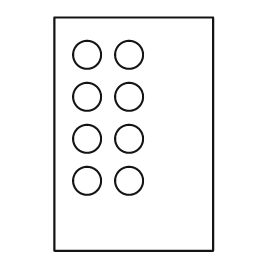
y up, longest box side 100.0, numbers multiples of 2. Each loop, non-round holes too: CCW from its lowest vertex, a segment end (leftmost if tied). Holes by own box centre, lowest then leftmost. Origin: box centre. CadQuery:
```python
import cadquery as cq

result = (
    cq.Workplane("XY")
    .moveTo(-34.0, -50.0)
    .lineTo(34.0, -50.0)
    .lineTo(34.0, 50.0)
    .lineTo(-34.0, 50.0)
    .close()
    .moveTo(-20.0, -20.0)
    .circle(6.0)
    .moveTo(-2.0, -20.0)
    .circle(6.0)
    .moveTo(-20.0, -2.0)
    .circle(6.0)
    .moveTo(-2.0, -2.0)
    .circle(6.0)
    .moveTo(-20.0, 16.0)
    .circle(6.0)
    .moveTo(-2.0, 16.0)
    .circle(6.0)
    .moveTo(-20.0, 34.0)
    .circle(6.0)
    .moveTo(-2.0, 34.0)
    .circle(6.0)
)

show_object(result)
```